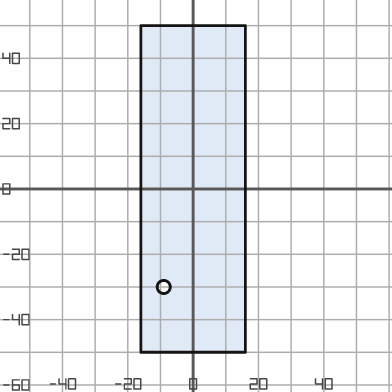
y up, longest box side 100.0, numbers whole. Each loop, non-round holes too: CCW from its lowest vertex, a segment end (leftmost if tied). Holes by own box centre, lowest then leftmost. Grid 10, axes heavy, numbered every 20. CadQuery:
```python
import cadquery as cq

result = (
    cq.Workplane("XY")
    .moveTo(-16.0, -50.0)
    .lineTo(16.0, -50.0)
    .lineTo(16.0, 50.0)
    .lineTo(-16.0, 50.0)
    .close()
    .moveTo(-9.0, -30.0)
    .circle(2.0)
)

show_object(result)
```